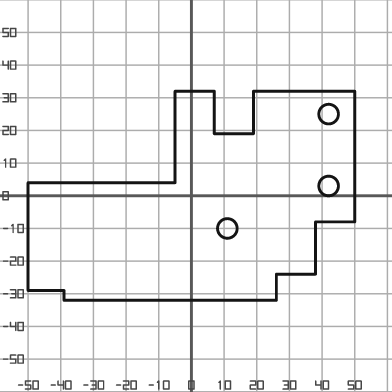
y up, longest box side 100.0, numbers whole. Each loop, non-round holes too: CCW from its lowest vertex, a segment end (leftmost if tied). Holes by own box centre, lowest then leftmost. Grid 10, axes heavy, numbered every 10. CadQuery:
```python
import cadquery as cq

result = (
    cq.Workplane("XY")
    .moveTo(-39.0, -32.0)
    .lineTo(26.0, -32.0)
    .lineTo(26.0, -24.0)
    .lineTo(38.0, -24.0)
    .lineTo(38.0, -8.0)
    .lineTo(50.0, -8.0)
    .lineTo(50.0, 32.0)
    .lineTo(19.0, 32.0)
    .lineTo(19.0, 19.0)
    .lineTo(7.0, 19.0)
    .lineTo(7.0, 32.0)
    .lineTo(-5.0, 32.0)
    .lineTo(-5.0, 4.0)
    .lineTo(-50.0, 4.0)
    .lineTo(-50.0, -29.0)
    .lineTo(-39.0, -29.0)
    .close()
    .moveTo(11.0, -10.0)
    .circle(3.0)
    .moveTo(42.0, 3.0)
    .circle(3.0)
    .moveTo(42.0, 25.0)
    .circle(3.0)
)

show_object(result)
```